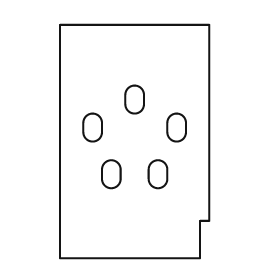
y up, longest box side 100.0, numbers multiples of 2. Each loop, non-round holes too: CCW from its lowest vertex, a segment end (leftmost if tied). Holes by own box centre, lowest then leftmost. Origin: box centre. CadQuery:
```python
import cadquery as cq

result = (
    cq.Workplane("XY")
    .moveTo(-32.0, -50.0)
    .lineTo(28.0, -50.0)
    .lineTo(28.0, -34.0)
    .lineTo(32.0, -34.0)
    .lineTo(32.0, 50.0)
    .lineTo(-32.0, 50.0)
    .close()
    .moveTo(-14.0, -16.0)
    .threePointArc((-10.0, -20.0), (-6.0, -16.0))
    .lineTo(-6.0, -12.0)
    .threePointArc((-10.0, -8.0), (-14.0, -12.0))
    .close()
    .moveTo(6.0, -16.0)
    .threePointArc((10.0, -20.0), (14.0, -16.0))
    .lineTo(14.0, -12.0)
    .threePointArc((10.0, -8.0), (6.0, -12.0))
    .close()
    .moveTo(-22.0, 4.0)
    .threePointArc((-18.0, 0.0), (-14.0, 4.0))
    .lineTo(-14.0, 8.0)
    .threePointArc((-18.0, 12.0), (-22.0, 8.0))
    .close()
    .moveTo(14.0, 4.0)
    .threePointArc((18.0, 0.0), (22.0, 4.0))
    .lineTo(22.0, 8.0)
    .threePointArc((18.0, 12.0), (14.0, 8.0))
    .close()
    .moveTo(-4.0, 16.0)
    .threePointArc((0.0, 12.0), (4.0, 16.0))
    .lineTo(4.0, 20.0)
    .threePointArc((0.0, 24.0), (-4.0, 20.0))
    .close()
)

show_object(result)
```